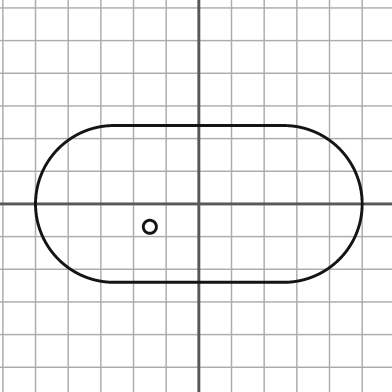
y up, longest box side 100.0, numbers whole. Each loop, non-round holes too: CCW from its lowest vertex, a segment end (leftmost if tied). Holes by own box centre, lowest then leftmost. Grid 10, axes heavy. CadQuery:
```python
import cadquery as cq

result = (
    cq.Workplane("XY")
    .moveTo(-26.0, -24.0)
    .lineTo(26.0, -24.0)
    .threePointArc((50.0, 0.0), (26.0, 24.0))
    .lineTo(-26.0, 24.0)
    .threePointArc((-50.0, 0.0), (-26.0, -24.0))
    .close()
    .moveTo(-15.0, -7.0)
    .circle(2.0)
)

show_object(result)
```